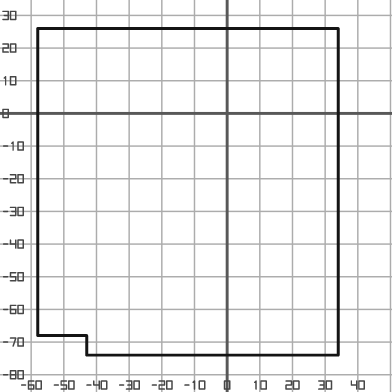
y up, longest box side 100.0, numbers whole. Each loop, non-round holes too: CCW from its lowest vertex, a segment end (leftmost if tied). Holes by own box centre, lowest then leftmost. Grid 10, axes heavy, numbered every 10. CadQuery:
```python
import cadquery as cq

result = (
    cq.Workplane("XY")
    .moveTo(-43.0, -74.0)
    .lineTo(34.0, -74.0)
    .lineTo(34.0, 26.0)
    .lineTo(-58.0, 26.0)
    .lineTo(-58.0, -68.0)
    .lineTo(-43.0, -68.0)
    .close()
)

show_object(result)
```